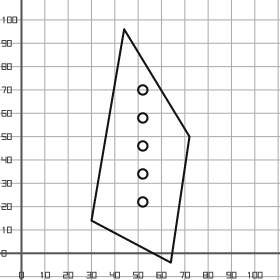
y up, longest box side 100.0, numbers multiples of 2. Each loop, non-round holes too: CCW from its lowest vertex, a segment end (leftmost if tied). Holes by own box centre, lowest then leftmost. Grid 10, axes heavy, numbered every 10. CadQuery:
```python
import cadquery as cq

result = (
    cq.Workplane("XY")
    .moveTo(64.0, -4.0)
    .lineTo(72.0, 50.0)
    .lineTo(44.0, 96.0)
    .lineTo(30.0, 14.0)
    .close()
    .moveTo(52.0, 22.0)
    .circle(2.0)
    .moveTo(52.0, 34.0)
    .circle(2.0)
    .moveTo(52.0, 46.0)
    .circle(2.0)
    .moveTo(52.0, 58.0)
    .circle(2.0)
    .moveTo(52.0, 70.0)
    .circle(2.0)
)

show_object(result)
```